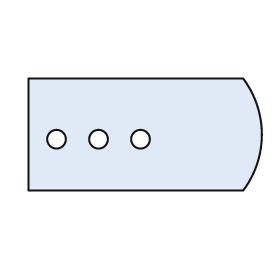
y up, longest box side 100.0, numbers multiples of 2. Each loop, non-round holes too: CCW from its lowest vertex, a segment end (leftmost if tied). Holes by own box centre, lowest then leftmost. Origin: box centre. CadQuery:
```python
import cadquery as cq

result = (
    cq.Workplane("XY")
    .moveTo(-50.0, -24.0)
    .lineTo(42.0, -24.0)
    .threePointArc((50.0, 0.0), (42.0, 24.0))
    .lineTo(-50.0, 24.0)
    .close()
    .moveTo(-38.0, -2.0)
    .circle(4.0)
    .moveTo(-20.0, -2.0)
    .circle(4.0)
    .moveTo(-2.0, -2.0)
    .circle(4.0)
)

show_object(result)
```